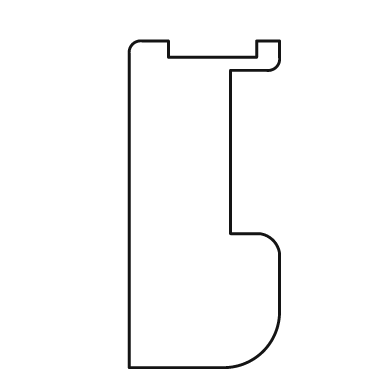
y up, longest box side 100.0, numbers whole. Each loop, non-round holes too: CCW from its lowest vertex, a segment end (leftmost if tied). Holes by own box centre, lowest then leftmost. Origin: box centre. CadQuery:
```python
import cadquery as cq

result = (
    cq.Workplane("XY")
    .moveTo(-23.0, -50.0)
    .lineTo(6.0, -50.0)
    .threePointArc((18.0, -45.0), (23.0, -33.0))
    .lineTo(23.0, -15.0)
    .threePointArc((21.0, -11.0), (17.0, -9.0))
    .lineTo(8.0, -9.0)
    .lineTo(8.0, 41.0)
    .lineTo(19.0, 41.0)
    .threePointArc((22.0, 42.0), (23.0, 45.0))
    .lineTo(23.0, 50.0)
    .lineTo(16.0, 50.0)
    .lineTo(16.0, 45.0)
    .lineTo(-11.0, 45.0)
    .lineTo(-11.0, 50.0)
    .lineTo(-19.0, 50.0)
    .threePointArc((-22.0, 49.0), (-23.0, 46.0))
    .close()
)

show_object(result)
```